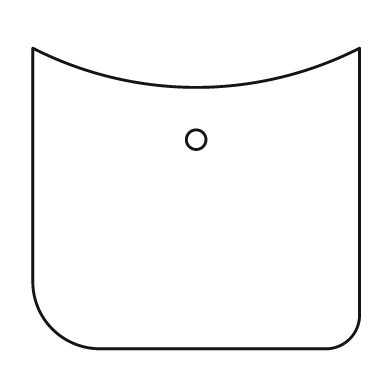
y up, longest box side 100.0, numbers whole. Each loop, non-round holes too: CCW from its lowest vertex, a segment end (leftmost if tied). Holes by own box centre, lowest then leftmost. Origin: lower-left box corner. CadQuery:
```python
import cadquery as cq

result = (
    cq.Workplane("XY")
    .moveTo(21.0, 0.0)
    .lineTo(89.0, 0.0)
    .threePointArc((97.0, 3.0), (100.0, 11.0))
    .lineTo(100.0, 92.0)
    .threePointArc((50.0, 80.0), (0.0, 92.0))
    .lineTo(0.0, 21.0)
    .threePointArc((6.0, 6.0), (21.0, 0.0))
    .close()
    .moveTo(50.0, 64.0)
    .circle(3.0)
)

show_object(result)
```